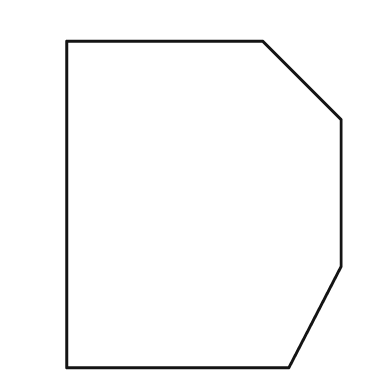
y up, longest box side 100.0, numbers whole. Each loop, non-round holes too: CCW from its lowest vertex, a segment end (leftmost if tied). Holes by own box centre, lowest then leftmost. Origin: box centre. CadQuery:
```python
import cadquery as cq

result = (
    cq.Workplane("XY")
    .moveTo(-42.0, -50.0)
    .lineTo(26.0, -50.0)
    .lineTo(42.0, -19.0)
    .lineTo(42.0, 26.0)
    .lineTo(18.0, 50.0)
    .lineTo(-42.0, 50.0)
    .close()
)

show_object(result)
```